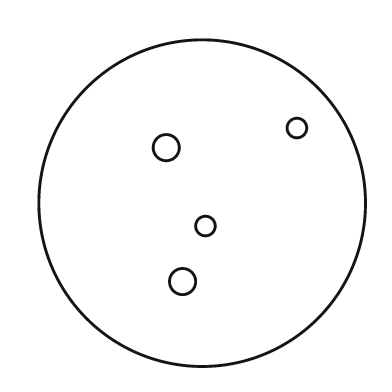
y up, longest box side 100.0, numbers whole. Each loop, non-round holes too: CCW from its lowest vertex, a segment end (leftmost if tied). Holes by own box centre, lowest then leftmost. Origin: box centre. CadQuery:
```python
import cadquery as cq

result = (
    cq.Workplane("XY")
    .moveTo(0.0, 0.0)
    .circle(50.0)
    .moveTo(-6.0, -24.0)
    .circle(4.0)
    .moveTo(1.0, -7.0)
    .circle(3.0)
    .moveTo(-11.0, 17.0)
    .circle(4.0)
    .moveTo(29.0, 23.0)
    .circle(3.0)
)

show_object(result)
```